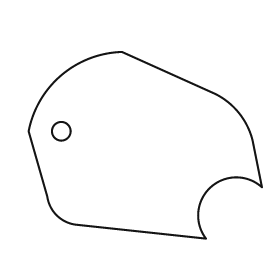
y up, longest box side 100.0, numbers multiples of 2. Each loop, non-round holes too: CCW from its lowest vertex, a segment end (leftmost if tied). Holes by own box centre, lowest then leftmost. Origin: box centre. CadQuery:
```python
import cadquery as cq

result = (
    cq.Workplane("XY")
    .moveTo(26.0, -40.0)
    .threePointArc((28.0, -18.0), (50.0, -18.0))
    .lineTo(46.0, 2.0)
    .threePointArc((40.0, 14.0), (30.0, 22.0))
    .lineTo(-10.0, 40.0)
    .threePointArc((-36.0, 30.0), (-50.0, 6.0))
    .lineTo(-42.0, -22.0)
    .threePointArc((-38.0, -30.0), (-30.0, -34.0))
    .close()
    .moveTo(-36.0, 6.0)
    .circle(4.0)
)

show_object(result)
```